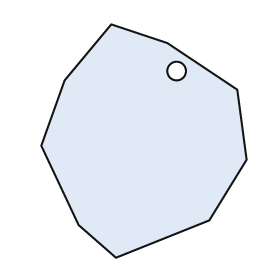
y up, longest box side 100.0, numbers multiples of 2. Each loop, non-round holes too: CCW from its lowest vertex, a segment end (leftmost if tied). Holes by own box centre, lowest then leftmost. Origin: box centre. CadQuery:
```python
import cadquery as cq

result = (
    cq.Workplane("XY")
    .moveTo(-12.0, -50.0)
    .lineTo(28.0, -34.0)
    .lineTo(44.0, -8.0)
    .lineTo(40.0, 22.0)
    .lineTo(10.0, 42.0)
    .lineTo(-14.0, 50.0)
    .lineTo(-34.0, 26.0)
    .lineTo(-44.0, -2.0)
    .lineTo(-28.0, -36.0)
    .close()
    .moveTo(14.0, 30.0)
    .circle(4.0)
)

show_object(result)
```